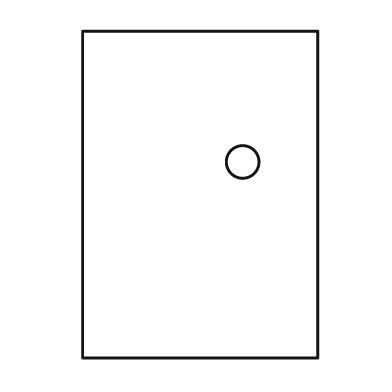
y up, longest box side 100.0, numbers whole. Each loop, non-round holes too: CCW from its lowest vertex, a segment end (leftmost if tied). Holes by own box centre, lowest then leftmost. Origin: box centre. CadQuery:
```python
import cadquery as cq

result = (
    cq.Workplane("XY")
    .moveTo(-36.0, -50.0)
    .lineTo(36.0, -50.0)
    .lineTo(36.0, 50.0)
    .lineTo(-36.0, 50.0)
    .close()
    .moveTo(13.0, 10.0)
    .circle(5.0)
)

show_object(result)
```